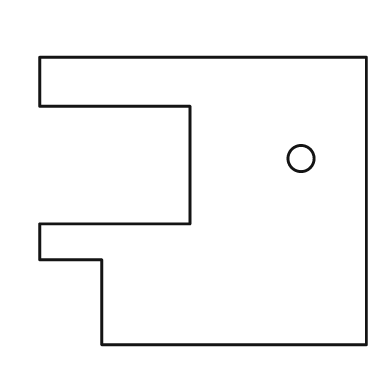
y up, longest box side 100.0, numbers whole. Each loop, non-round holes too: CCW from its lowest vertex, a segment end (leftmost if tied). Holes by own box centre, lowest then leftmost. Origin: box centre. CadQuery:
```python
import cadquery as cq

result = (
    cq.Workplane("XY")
    .moveTo(-31.0, -44.0)
    .lineTo(50.0, -44.0)
    .lineTo(50.0, 44.0)
    .lineTo(-50.0, 44.0)
    .lineTo(-50.0, 29.0)
    .lineTo(-4.0, 29.0)
    .lineTo(-4.0, -7.0)
    .lineTo(-50.0, -7.0)
    .lineTo(-50.0, -18.0)
    .lineTo(-31.0, -18.0)
    .close()
    .moveTo(30.0, 13.0)
    .circle(4.0)
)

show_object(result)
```